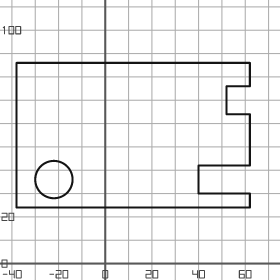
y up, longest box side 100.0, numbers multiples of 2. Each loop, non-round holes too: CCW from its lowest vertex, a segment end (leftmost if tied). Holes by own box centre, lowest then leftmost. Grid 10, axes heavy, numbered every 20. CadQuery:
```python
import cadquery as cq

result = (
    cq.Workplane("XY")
    .moveTo(-38.0, 24.0)
    .lineTo(62.0, 24.0)
    .lineTo(62.0, 30.0)
    .lineTo(40.0, 30.0)
    .lineTo(40.0, 42.0)
    .lineTo(62.0, 42.0)
    .lineTo(62.0, 64.0)
    .lineTo(52.0, 64.0)
    .lineTo(52.0, 76.0)
    .lineTo(62.0, 76.0)
    .lineTo(62.0, 86.0)
    .lineTo(-38.0, 86.0)
    .close()
    .moveTo(-22.0, 36.0)
    .circle(8.0)
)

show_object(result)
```